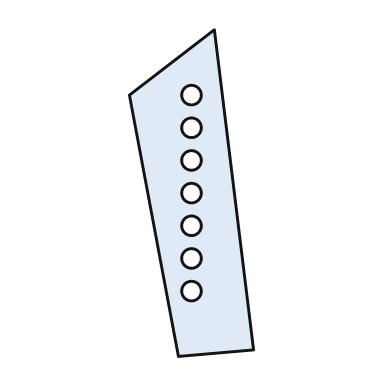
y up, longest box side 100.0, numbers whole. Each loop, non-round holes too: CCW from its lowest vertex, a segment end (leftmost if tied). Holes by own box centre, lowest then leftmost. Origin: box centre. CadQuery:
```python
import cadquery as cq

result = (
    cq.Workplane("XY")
    .moveTo(-4.0, -50.0)
    .lineTo(19.0, -48.0)
    .lineTo(7.0, 50.0)
    .lineTo(-19.0, 30.0)
    .close()
    .moveTo(0.0, -30.0)
    .circle(3.0)
    .moveTo(0.0, -20.0)
    .circle(3.0)
    .moveTo(0.0, -10.0)
    .circle(3.0)
    .moveTo(0.0, 0.0)
    .circle(3.0)
    .moveTo(0.0, 10.0)
    .circle(3.0)
    .moveTo(0.0, 20.0)
    .circle(3.0)
    .moveTo(0.0, 30.0)
    .circle(3.0)
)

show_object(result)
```